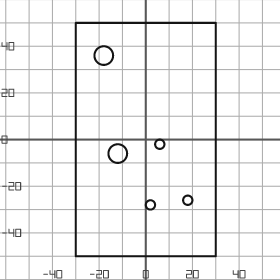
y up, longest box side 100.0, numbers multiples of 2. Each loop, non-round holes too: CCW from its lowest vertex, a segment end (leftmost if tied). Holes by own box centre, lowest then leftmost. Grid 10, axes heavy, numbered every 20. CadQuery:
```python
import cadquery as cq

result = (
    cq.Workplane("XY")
    .moveTo(-30.0, -50.0)
    .lineTo(30.0, -50.0)
    .lineTo(30.0, 50.0)
    .lineTo(-30.0, 50.0)
    .close()
    .moveTo(2.0, -28.0)
    .circle(2.0)
    .moveTo(18.0, -26.0)
    .circle(2.0)
    .moveTo(-12.0, -6.0)
    .circle(4.0)
    .moveTo(6.0, -2.0)
    .circle(2.0)
    .moveTo(-18.0, 36.0)
    .circle(4.0)
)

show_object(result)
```